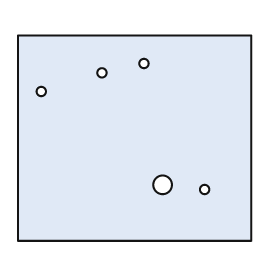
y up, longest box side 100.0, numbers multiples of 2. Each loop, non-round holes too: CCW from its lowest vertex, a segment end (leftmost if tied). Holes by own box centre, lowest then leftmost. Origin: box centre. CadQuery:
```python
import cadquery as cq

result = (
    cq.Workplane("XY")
    .moveTo(-50.0, -44.0)
    .lineTo(50.0, -44.0)
    .lineTo(50.0, 44.0)
    .lineTo(-50.0, 44.0)
    .close()
    .moveTo(30.0, -22.0)
    .circle(2.0)
    .moveTo(12.0, -20.0)
    .circle(4.0)
    .moveTo(-40.0, 20.0)
    .circle(2.0)
    .moveTo(-14.0, 28.0)
    .circle(2.0)
    .moveTo(4.0, 32.0)
    .circle(2.0)
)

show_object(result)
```